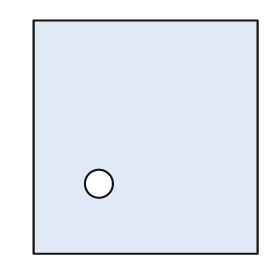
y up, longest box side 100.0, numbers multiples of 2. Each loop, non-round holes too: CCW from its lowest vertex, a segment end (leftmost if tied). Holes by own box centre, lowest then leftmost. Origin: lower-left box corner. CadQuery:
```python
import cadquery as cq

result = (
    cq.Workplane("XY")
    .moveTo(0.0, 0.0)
    .lineTo(96.0, 0.0)
    .lineTo(96.0, 100.0)
    .lineTo(0.0, 100.0)
    .close()
    .moveTo(28.0, 30.0)
    .circle(6.0)
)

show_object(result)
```